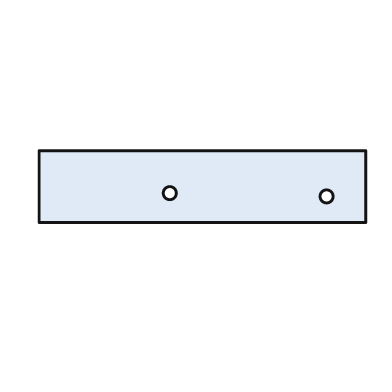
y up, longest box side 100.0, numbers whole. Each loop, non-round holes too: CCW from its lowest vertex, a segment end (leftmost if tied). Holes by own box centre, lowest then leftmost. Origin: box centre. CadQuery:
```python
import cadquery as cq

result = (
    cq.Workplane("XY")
    .moveTo(-50.0, -11.0)
    .lineTo(50.0, -11.0)
    .lineTo(50.0, 11.0)
    .lineTo(-50.0, 11.0)
    .close()
    .moveTo(38.0, -3.0)
    .circle(2.0)
    .moveTo(-10.0, -2.0)
    .circle(2.0)
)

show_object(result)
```